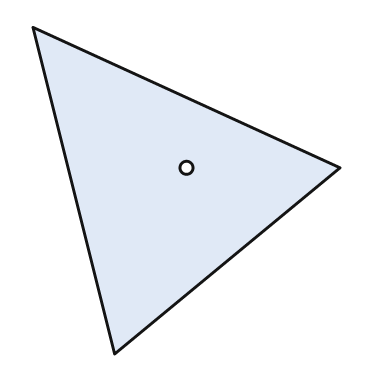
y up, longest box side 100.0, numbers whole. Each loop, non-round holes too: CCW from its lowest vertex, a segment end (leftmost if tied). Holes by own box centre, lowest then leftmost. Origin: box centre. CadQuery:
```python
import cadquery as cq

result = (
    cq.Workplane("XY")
    .moveTo(-22.0, -50.0)
    .lineTo(47.0, 7.0)
    .lineTo(-47.0, 50.0)
    .close()
    .moveTo(0.0, 7.0)
    .circle(2.0)
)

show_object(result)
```